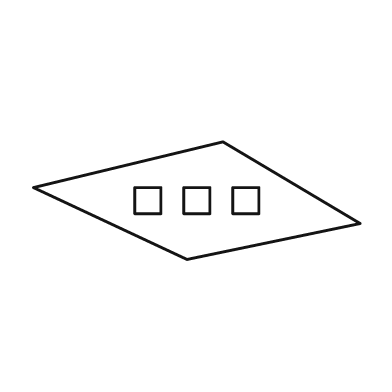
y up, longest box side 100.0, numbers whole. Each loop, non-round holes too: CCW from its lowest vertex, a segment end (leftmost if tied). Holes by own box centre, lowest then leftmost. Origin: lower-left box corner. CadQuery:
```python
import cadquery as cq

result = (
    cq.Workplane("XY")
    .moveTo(47.0, 0.0)
    .lineTo(100.0, 11.0)
    .lineTo(58.0, 36.0)
    .lineTo(0.0, 22.0)
    .close()
    .moveTo(31.0, 14.0)
    .lineTo(39.0, 14.0)
    .lineTo(39.0, 22.0)
    .lineTo(31.0, 22.0)
    .close()
    .moveTo(46.0, 14.0)
    .lineTo(54.0, 14.0)
    .lineTo(54.0, 22.0)
    .lineTo(46.0, 22.0)
    .close()
    .moveTo(61.0, 14.0)
    .lineTo(69.0, 14.0)
    .lineTo(69.0, 22.0)
    .lineTo(61.0, 22.0)
    .close()
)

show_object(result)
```